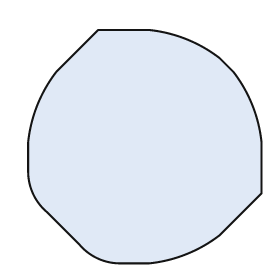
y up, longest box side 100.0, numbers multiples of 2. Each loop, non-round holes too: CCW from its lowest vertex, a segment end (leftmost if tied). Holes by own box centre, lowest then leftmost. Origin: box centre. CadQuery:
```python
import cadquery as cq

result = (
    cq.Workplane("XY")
    .moveTo(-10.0, -50.0)
    .lineTo(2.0, -50.0)
    .threePointArc((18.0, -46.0), (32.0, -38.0))
    .lineTo(50.0, -20.0)
    .lineTo(50.0, 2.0)
    .threePointArc((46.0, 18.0), (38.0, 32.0))
    .lineTo(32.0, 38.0)
    .threePointArc((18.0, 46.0), (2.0, 50.0))
    .lineTo(-20.0, 50.0)
    .lineTo(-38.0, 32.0)
    .threePointArc((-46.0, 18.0), (-50.0, 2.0))
    .lineTo(-50.0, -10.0)
    .threePointArc((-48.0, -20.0), (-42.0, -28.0))
    .lineTo(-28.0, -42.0)
    .threePointArc((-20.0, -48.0), (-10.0, -50.0))
    .close()
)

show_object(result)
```